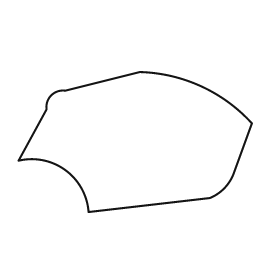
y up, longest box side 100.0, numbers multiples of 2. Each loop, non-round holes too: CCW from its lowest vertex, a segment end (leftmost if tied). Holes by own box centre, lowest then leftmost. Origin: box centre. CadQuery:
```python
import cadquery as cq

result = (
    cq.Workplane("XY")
    .moveTo(-20.0, -30.0)
    .lineTo(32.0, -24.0)
    .threePointArc((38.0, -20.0), (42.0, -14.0))
    .lineTo(50.0, 8.0)
    .threePointArc((28.0, 24.0), (2.0, 30.0))
    .lineTo(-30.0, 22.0)
    .threePointArc((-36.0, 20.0), (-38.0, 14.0))
    .lineTo(-50.0, -8.0)
    .threePointArc((-30.0, -12.0), (-20.0, -30.0))
    .close()
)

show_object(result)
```